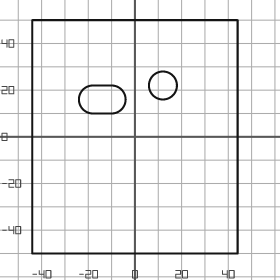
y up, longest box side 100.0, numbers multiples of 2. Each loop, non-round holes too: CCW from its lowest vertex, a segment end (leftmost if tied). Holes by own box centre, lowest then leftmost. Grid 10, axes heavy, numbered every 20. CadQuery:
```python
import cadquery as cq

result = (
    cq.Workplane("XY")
    .moveTo(-44.0, -50.0)
    .lineTo(44.0, -50.0)
    .lineTo(44.0, 50.0)
    .lineTo(-44.0, 50.0)
    .close()
    .moveTo(-18.0, 10.0)
    .lineTo(-10.0, 10.0)
    .threePointArc((-4.0, 16.0), (-10.0, 22.0))
    .lineTo(-18.0, 22.0)
    .threePointArc((-24.0, 16.0), (-18.0, 10.0))
    .close()
    .moveTo(12.0, 22.0)
    .circle(6.0)
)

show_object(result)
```